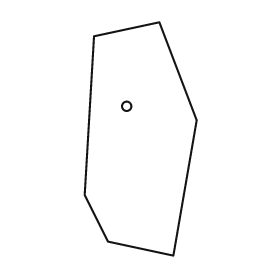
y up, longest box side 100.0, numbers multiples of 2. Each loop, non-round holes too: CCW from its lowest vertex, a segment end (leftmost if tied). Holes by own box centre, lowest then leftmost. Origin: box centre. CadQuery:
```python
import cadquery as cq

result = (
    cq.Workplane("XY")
    .moveTo(14.0, -50.0)
    .lineTo(24.0, 8.0)
    .lineTo(8.0, 50.0)
    .lineTo(-20.0, 44.0)
    .lineTo(-24.0, -24.0)
    .lineTo(-14.0, -44.0)
    .close()
    .moveTo(-6.0, 14.0)
    .circle(2.0)
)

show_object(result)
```